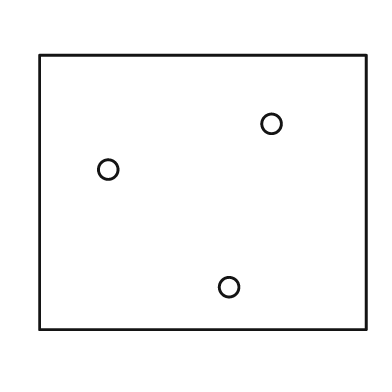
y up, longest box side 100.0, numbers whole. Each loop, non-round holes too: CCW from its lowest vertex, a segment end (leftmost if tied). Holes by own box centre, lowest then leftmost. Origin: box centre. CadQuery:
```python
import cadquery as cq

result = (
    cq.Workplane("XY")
    .moveTo(-50.0, -42.0)
    .lineTo(50.0, -42.0)
    .lineTo(50.0, 42.0)
    .lineTo(-50.0, 42.0)
    .close()
    .moveTo(8.0, -29.0)
    .circle(3.0)
    .moveTo(-29.0, 7.0)
    .circle(3.0)
    .moveTo(21.0, 21.0)
    .circle(3.0)
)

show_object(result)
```